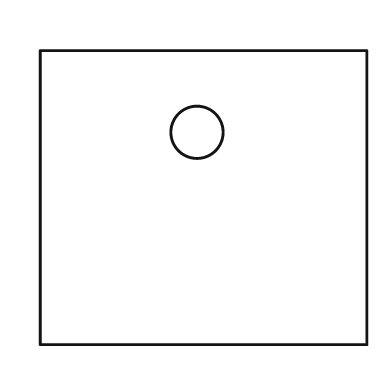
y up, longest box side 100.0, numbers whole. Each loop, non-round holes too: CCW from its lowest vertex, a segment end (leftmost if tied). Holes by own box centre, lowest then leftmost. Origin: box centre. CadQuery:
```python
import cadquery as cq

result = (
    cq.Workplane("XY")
    .moveTo(-50.0, -45.0)
    .lineTo(50.0, -45.0)
    .lineTo(50.0, 45.0)
    .lineTo(-50.0, 45.0)
    .close()
    .moveTo(-2.0, 20.0)
    .circle(8.0)
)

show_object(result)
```